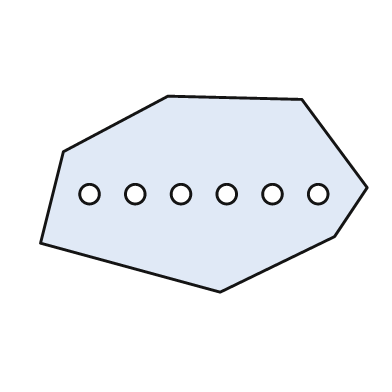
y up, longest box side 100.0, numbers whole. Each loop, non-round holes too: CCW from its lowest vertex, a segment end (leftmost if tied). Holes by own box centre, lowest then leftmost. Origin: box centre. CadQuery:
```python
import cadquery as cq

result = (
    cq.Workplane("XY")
    .moveTo(5.0, -30.0)
    .lineTo(40.0, -13.0)
    .lineTo(50.0, 2.0)
    .lineTo(30.0, 29.0)
    .lineTo(-11.0, 30.0)
    .lineTo(-43.0, 13.0)
    .lineTo(-50.0, -15.0)
    .close()
    .moveTo(-35.0, 0.0)
    .circle(3.0)
    .moveTo(-21.0, 0.0)
    .circle(3.0)
    .moveTo(-7.0, 0.0)
    .circle(3.0)
    .moveTo(7.0, 0.0)
    .circle(3.0)
    .moveTo(21.0, 0.0)
    .circle(3.0)
    .moveTo(35.0, 0.0)
    .circle(3.0)
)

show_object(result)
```